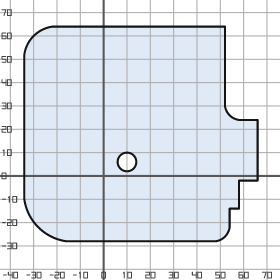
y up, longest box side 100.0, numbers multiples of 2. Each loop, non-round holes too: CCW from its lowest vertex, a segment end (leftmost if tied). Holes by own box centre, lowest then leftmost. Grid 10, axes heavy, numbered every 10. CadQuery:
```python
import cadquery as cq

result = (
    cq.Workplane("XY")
    .moveTo(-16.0, -28.0)
    .lineTo(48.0, -28.0)
    .threePointArc((52.0, -26.0), (54.0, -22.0))
    .lineTo(54.0, -14.0)
    .lineTo(58.0, -14.0)
    .lineTo(58.0, -2.0)
    .lineTo(66.0, -2.0)
    .lineTo(66.0, 24.0)
    .lineTo(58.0, 24.0)
    .threePointArc((54.0, 26.0), (52.0, 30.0))
    .lineTo(52.0, 64.0)
    .lineTo(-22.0, 64.0)
    .threePointArc((-30.0, 60.0), (-34.0, 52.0))
    .lineTo(-34.0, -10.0)
    .threePointArc((-28.0, -22.0), (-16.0, -28.0))
    .close()
    .moveTo(10.0, 6.0)
    .circle(4.0)
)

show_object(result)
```